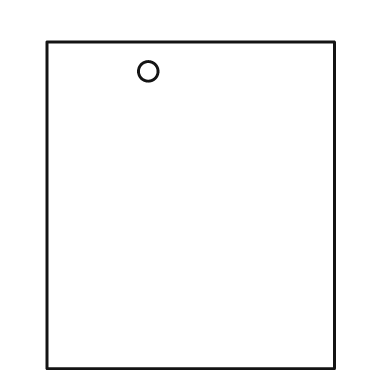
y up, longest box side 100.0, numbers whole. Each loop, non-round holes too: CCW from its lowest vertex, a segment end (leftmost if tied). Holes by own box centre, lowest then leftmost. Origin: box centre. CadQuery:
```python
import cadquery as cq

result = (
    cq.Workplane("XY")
    .moveTo(-44.0, -50.0)
    .lineTo(44.0, -50.0)
    .lineTo(44.0, 50.0)
    .lineTo(-44.0, 50.0)
    .close()
    .moveTo(-13.0, 41.0)
    .circle(3.0)
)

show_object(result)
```